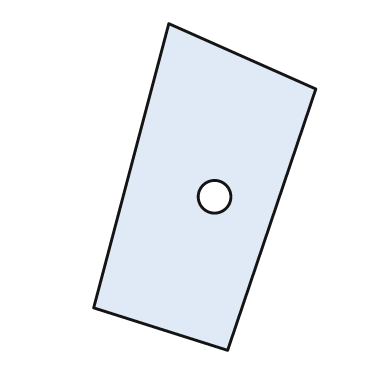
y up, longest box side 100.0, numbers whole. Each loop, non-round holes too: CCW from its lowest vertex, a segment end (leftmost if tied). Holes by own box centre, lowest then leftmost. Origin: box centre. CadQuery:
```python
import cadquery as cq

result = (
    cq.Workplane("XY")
    .moveTo(7.0, -50.0)
    .lineTo(34.0, 30.0)
    .lineTo(-11.0, 50.0)
    .lineTo(-34.0, -37.0)
    .close()
    .moveTo(3.0, -3.0)
    .circle(5.0)
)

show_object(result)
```